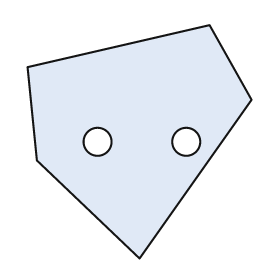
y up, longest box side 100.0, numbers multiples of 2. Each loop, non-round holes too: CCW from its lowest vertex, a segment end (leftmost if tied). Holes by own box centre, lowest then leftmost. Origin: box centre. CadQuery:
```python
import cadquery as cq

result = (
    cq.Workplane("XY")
    .moveTo(0.0, -50.0)
    .lineTo(48.0, 18.0)
    .lineTo(30.0, 50.0)
    .lineTo(-48.0, 32.0)
    .lineTo(-44.0, -8.0)
    .close()
    .moveTo(-18.0, 0.0)
    .circle(6.0)
    .moveTo(20.0, 0.0)
    .circle(6.0)
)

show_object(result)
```